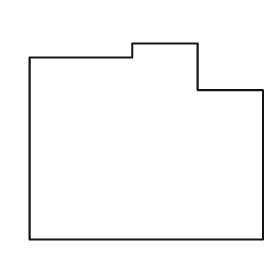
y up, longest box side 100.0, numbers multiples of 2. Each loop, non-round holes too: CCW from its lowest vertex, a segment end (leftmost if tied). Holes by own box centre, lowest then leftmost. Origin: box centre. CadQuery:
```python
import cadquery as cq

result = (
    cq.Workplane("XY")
    .moveTo(-50.0, -42.0)
    .lineTo(50.0, -42.0)
    .lineTo(50.0, 22.0)
    .lineTo(22.0, 22.0)
    .lineTo(22.0, 42.0)
    .lineTo(-6.0, 42.0)
    .lineTo(-6.0, 36.0)
    .lineTo(-50.0, 36.0)
    .close()
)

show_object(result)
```